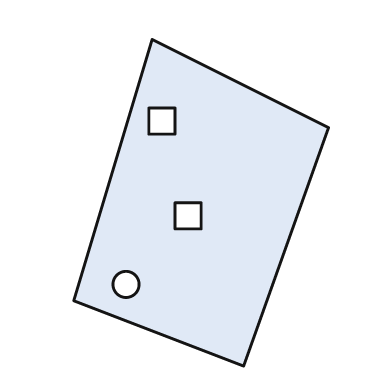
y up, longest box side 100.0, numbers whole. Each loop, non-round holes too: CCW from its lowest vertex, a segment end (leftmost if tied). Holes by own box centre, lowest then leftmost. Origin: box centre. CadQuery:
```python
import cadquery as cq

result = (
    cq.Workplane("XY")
    .moveTo(13.0, -50.0)
    .lineTo(39.0, 23.0)
    .lineTo(-15.0, 50.0)
    .lineTo(-39.0, -30.0)
    .close()
    .moveTo(-23.0, -25.0)
    .circle(4.0)
    .moveTo(-8.0, -8.0)
    .lineTo(0.0, -8.0)
    .lineTo(0.0, 0.0)
    .lineTo(-8.0, 0.0)
    .close()
    .moveTo(-16.0, 21.0)
    .lineTo(-8.0, 21.0)
    .lineTo(-8.0, 29.0)
    .lineTo(-16.0, 29.0)
    .close()
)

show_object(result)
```